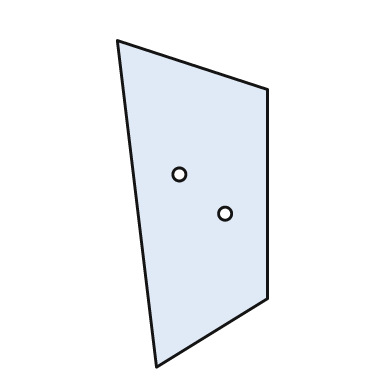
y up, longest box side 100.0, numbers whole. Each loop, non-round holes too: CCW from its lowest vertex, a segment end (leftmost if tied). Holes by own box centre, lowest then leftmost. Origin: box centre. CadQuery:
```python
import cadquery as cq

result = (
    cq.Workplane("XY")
    .moveTo(-11.0, -50.0)
    .lineTo(23.0, -29.0)
    .lineTo(23.0, 35.0)
    .lineTo(-23.0, 50.0)
    .close()
    .moveTo(10.0, -3.0)
    .circle(2.0)
    .moveTo(-4.0, 9.0)
    .circle(2.0)
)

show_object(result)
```